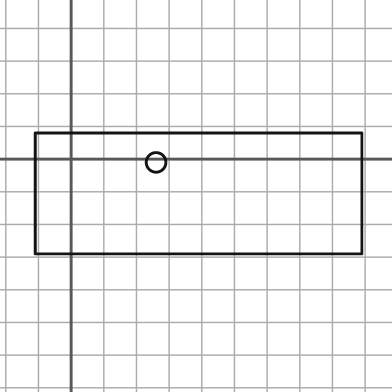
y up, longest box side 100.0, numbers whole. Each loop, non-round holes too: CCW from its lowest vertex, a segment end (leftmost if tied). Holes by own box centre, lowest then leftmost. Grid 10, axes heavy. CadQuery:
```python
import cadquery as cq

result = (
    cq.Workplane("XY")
    .moveTo(-11.0, -29.0)
    .lineTo(89.0, -29.0)
    .lineTo(89.0, 8.0)
    .lineTo(-11.0, 8.0)
    .close()
    .moveTo(26.0, -1.0)
    .circle(3.0)
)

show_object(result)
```